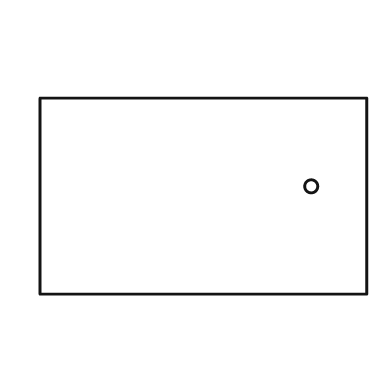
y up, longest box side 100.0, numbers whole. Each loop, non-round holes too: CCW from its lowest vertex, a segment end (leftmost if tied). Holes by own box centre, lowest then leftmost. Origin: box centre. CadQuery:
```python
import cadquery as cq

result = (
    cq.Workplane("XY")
    .moveTo(-50.0, -30.0)
    .lineTo(50.0, -30.0)
    .lineTo(50.0, 30.0)
    .lineTo(-50.0, 30.0)
    .close()
    .moveTo(33.0, 3.0)
    .circle(2.0)
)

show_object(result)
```